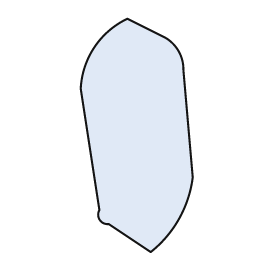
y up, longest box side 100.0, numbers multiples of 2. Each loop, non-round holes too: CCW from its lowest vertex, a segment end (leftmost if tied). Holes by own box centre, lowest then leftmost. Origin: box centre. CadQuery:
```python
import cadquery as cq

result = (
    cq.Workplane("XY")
    .moveTo(6.0, -50.0)
    .threePointArc((18.0, -36.0), (24.0, -18.0))
    .lineTo(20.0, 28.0)
    .threePointArc((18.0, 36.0), (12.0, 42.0))
    .lineTo(-4.0, 50.0)
    .threePointArc((-18.0, 38.0), (-24.0, 20.0))
    .lineTo(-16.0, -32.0)
    .threePointArc((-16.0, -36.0), (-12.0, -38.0))
    .close()
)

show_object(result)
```